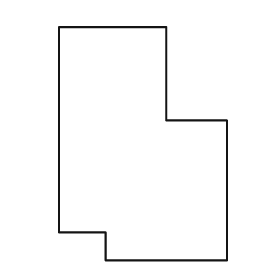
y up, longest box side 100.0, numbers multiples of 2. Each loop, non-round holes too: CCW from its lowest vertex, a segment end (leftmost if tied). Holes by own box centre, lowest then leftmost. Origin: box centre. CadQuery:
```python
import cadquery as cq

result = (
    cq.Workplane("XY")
    .moveTo(-16.0, -50.0)
    .lineTo(36.0, -50.0)
    .lineTo(36.0, 10.0)
    .lineTo(10.0, 10.0)
    .lineTo(10.0, 50.0)
    .lineTo(-36.0, 50.0)
    .lineTo(-36.0, -38.0)
    .lineTo(-16.0, -38.0)
    .close()
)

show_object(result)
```